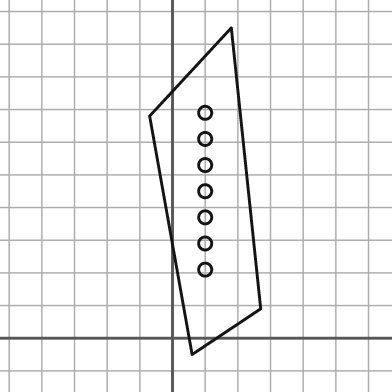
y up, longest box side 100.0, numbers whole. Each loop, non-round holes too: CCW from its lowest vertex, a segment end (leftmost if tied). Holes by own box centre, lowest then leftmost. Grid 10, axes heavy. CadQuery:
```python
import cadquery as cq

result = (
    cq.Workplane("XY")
    .moveTo(6.0, -5.0)
    .lineTo(27.0, 9.0)
    .lineTo(18.0, 95.0)
    .lineTo(-7.0, 68.0)
    .close()
    .moveTo(10.0, 21.0)
    .circle(2.0)
    .moveTo(10.0, 29.0)
    .circle(2.0)
    .moveTo(10.0, 37.0)
    .circle(2.0)
    .moveTo(10.0, 45.0)
    .circle(2.0)
    .moveTo(10.0, 53.0)
    .circle(2.0)
    .moveTo(10.0, 61.0)
    .circle(2.0)
    .moveTo(10.0, 69.0)
    .circle(2.0)
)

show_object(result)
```